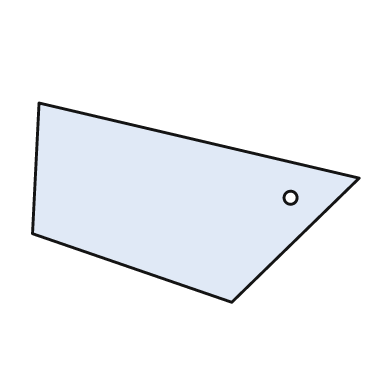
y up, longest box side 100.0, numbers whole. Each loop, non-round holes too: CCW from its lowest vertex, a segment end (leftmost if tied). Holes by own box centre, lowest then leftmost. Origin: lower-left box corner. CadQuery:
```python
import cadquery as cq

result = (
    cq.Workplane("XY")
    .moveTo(61.0, 0.0)
    .lineTo(100.0, 38.0)
    .lineTo(2.0, 61.0)
    .lineTo(0.0, 21.0)
    .close()
    .moveTo(79.0, 32.0)
    .circle(2.0)
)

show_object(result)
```